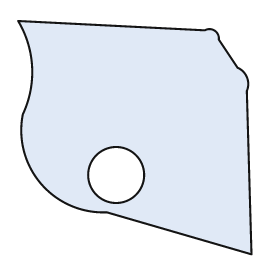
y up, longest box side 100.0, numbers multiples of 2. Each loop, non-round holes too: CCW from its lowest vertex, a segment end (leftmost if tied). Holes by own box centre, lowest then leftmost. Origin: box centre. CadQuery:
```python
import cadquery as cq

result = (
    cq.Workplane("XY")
    .moveTo(50.0, -50.0)
    .lineTo(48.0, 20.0)
    .threePointArc((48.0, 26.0), (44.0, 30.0))
    .lineTo(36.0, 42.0)
    .threePointArc((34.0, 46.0), (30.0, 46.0))
    .lineTo(-50.0, 50.0)
    .threePointArc((-44.0, 30.0), (-48.0, 10.0))
    .threePointArc((-40.0, -20.0), (-12.0, -32.0))
    .close()
    .moveTo(-8.0, -16.0)
    .circle(12.0)
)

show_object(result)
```